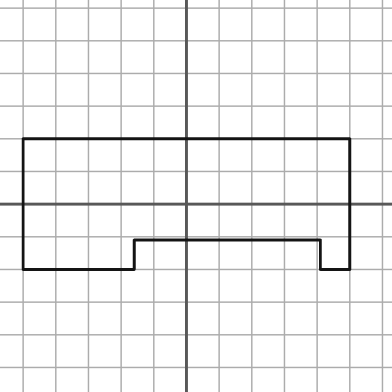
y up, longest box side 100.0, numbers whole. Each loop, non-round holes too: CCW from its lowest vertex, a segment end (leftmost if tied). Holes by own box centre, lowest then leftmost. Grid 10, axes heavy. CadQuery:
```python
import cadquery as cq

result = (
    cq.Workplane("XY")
    .moveTo(-50.0, -20.0)
    .lineTo(-16.0, -20.0)
    .lineTo(-16.0, -11.0)
    .lineTo(41.0, -11.0)
    .lineTo(41.0, -20.0)
    .lineTo(50.0, -20.0)
    .lineTo(50.0, 20.0)
    .lineTo(-50.0, 20.0)
    .close()
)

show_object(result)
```